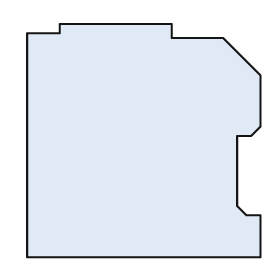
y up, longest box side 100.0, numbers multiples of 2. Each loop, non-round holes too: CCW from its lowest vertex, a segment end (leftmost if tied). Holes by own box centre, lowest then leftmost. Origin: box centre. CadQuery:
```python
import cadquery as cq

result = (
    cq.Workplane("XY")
    .moveTo(-50.0, -50.0)
    .lineTo(50.0, -50.0)
    .lineTo(50.0, -32.0)
    .lineTo(44.0, -32.0)
    .lineTo(40.0, -28.0)
    .lineTo(40.0, 2.0)
    .lineTo(46.0, 2.0)
    .lineTo(50.0, 6.0)
    .lineTo(50.0, 28.0)
    .lineTo(34.0, 44.0)
    .lineTo(12.0, 44.0)
    .lineTo(12.0, 50.0)
    .lineTo(-36.0, 50.0)
    .lineTo(-36.0, 46.0)
    .lineTo(-50.0, 46.0)
    .close()
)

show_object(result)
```